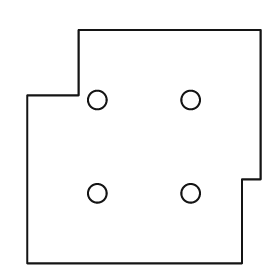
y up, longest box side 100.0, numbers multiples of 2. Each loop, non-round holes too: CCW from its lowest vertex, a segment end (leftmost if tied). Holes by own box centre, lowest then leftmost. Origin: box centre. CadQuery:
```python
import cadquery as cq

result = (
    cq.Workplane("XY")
    .moveTo(-50.0, -50.0)
    .lineTo(42.0, -50.0)
    .lineTo(42.0, -14.0)
    .lineTo(50.0, -14.0)
    .lineTo(50.0, 50.0)
    .lineTo(-28.0, 50.0)
    .lineTo(-28.0, 22.0)
    .lineTo(-50.0, 22.0)
    .close()
    .moveTo(-20.0, -20.0)
    .circle(4.0)
    .moveTo(20.0, -20.0)
    .circle(4.0)
    .moveTo(-20.0, 20.0)
    .circle(4.0)
    .moveTo(20.0, 20.0)
    .circle(4.0)
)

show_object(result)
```